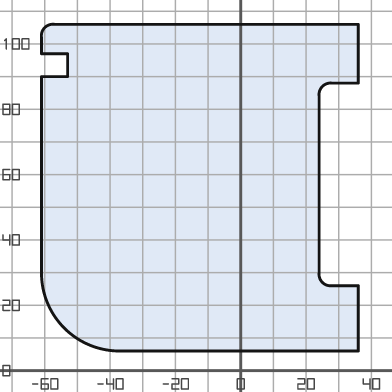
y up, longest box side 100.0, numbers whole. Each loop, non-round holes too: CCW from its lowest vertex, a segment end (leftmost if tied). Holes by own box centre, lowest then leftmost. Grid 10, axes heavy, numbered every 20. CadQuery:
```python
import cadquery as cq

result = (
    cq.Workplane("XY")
    .moveTo(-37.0, 6.0)
    .lineTo(36.0, 6.0)
    .lineTo(36.0, 26.0)
    .lineTo(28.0, 26.0)
    .threePointArc((25.0, 27.0), (24.0, 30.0))
    .lineTo(24.0, 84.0)
    .threePointArc((25.0, 87.0), (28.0, 88.0))
    .lineTo(36.0, 88.0)
    .lineTo(36.0, 106.0)
    .lineTo(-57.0, 106.0)
    .threePointArc((-60.0, 105.0), (-61.0, 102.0))
    .lineTo(-61.0, 97.0)
    .lineTo(-53.0, 97.0)
    .lineTo(-53.0, 90.0)
    .lineTo(-61.0, 90.0)
    .lineTo(-61.0, 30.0)
    .threePointArc((-54.0, 13.0), (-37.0, 6.0))
    .close()
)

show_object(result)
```